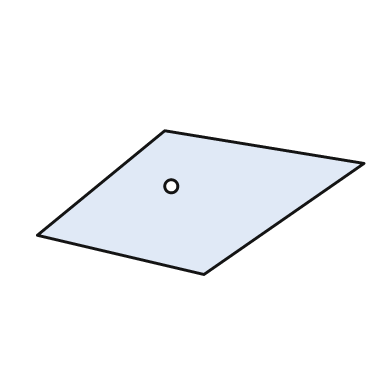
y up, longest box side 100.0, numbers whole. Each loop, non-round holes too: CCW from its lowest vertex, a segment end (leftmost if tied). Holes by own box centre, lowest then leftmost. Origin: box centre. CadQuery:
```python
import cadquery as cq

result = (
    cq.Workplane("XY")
    .moveTo(1.0, -22.0)
    .lineTo(50.0, 12.0)
    .lineTo(-11.0, 22.0)
    .lineTo(-50.0, -10.0)
    .close()
    .moveTo(-9.0, 5.0)
    .circle(2.0)
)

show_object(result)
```